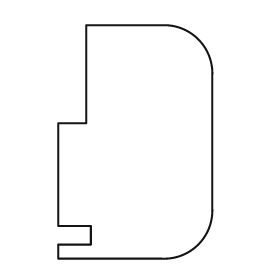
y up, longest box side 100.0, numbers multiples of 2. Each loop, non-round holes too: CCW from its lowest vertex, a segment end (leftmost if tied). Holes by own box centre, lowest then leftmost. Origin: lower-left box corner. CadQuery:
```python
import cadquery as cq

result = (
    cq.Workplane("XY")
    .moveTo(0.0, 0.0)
    .lineTo(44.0, 0.0)
    .threePointArc((60.0, 6.0), (66.0, 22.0))
    .lineTo(66.0, 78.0)
    .threePointArc((60.0, 94.0), (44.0, 100.0))
    .lineTo(12.0, 100.0)
    .lineTo(12.0, 58.0)
    .lineTo(0.0, 58.0)
    .lineTo(0.0, 14.0)
    .lineTo(14.0, 14.0)
    .lineTo(14.0, 6.0)
    .lineTo(0.0, 6.0)
    .close()
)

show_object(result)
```